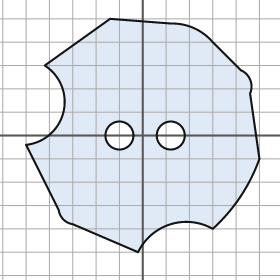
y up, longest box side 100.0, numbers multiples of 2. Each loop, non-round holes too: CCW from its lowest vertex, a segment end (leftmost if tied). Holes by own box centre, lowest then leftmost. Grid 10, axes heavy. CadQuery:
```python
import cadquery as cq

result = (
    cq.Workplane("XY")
    .moveTo(-2.0, -50.0)
    .threePointArc((12.0, -38.0), (30.0, -40.0))
    .threePointArc((42.0, -26.0), (50.0, -10.0))
    .lineTo(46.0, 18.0)
    .threePointArc((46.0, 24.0), (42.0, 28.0))
    .lineTo(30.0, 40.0)
    .threePointArc((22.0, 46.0), (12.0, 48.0))
    .lineTo(-14.0, 50.0)
    .lineTo(-42.0, 30.0)
    .threePointArc((-34.0, 10.0), (-50.0, -4.0))
    .lineTo(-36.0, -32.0)
    .threePointArc((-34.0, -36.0), (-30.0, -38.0))
    .close()
    .moveTo(-10.0, 0.0)
    .circle(6.0)
    .moveTo(12.0, 0.0)
    .circle(6.0)
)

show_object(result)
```